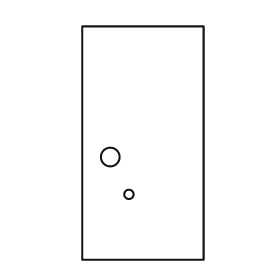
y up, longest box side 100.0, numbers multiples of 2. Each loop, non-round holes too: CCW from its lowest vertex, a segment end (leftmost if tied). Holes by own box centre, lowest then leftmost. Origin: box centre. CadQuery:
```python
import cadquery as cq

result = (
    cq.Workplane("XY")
    .moveTo(-26.0, -50.0)
    .lineTo(26.0, -50.0)
    .lineTo(26.0, 50.0)
    .lineTo(-26.0, 50.0)
    .close()
    .moveTo(-6.0, -22.0)
    .circle(2.0)
    .moveTo(-14.0, -6.0)
    .circle(4.0)
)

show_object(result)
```